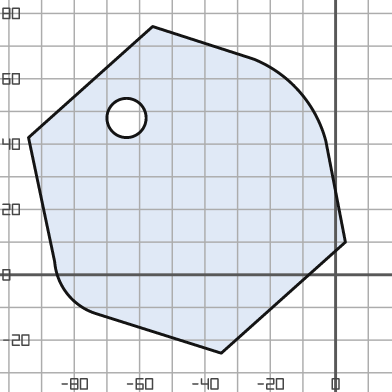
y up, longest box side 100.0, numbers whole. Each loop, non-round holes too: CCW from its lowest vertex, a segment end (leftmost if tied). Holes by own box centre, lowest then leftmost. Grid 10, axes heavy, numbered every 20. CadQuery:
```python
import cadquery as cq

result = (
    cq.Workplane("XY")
    .moveTo(-35.0, -24.0)
    .lineTo(3.0, 10.0)
    .lineTo(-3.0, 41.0)
    .threePointArc((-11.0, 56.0), (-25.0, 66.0))
    .lineTo(-56.0, 76.0)
    .lineTo(-94.0, 42.0)
    .lineTo(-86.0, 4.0)
    .threePointArc((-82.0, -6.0), (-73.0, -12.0))
    .close()
    .moveTo(-64.0, 48.0)
    .circle(6.0)
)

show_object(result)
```